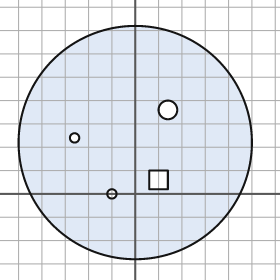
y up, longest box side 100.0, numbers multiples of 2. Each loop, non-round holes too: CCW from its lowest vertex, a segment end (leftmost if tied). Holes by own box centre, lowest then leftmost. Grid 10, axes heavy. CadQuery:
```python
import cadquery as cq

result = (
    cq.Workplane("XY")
    .moveTo(0.0, 22.0)
    .circle(50.0)
    .moveTo(-10.0, 0.0)
    .circle(2.0)
    .moveTo(6.0, 2.0)
    .lineTo(14.0, 2.0)
    .lineTo(14.0, 10.0)
    .lineTo(6.0, 10.0)
    .close()
    .moveTo(-26.0, 24.0)
    .circle(2.0)
    .moveTo(14.0, 36.0)
    .circle(4.0)
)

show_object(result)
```